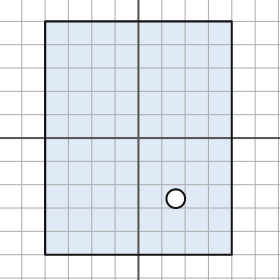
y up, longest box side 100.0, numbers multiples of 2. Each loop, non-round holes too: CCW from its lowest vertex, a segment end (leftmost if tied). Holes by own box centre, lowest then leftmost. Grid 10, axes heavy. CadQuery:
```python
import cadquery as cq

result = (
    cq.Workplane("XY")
    .moveTo(-40.0, -50.0)
    .lineTo(40.0, -50.0)
    .lineTo(40.0, 50.0)
    .lineTo(-40.0, 50.0)
    .close()
    .moveTo(16.0, -26.0)
    .circle(4.0)
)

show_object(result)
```